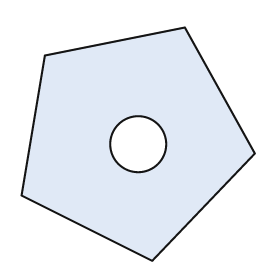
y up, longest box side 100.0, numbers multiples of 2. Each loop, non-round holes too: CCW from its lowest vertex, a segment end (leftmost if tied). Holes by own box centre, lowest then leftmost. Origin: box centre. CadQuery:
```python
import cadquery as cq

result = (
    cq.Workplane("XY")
    .moveTo(6.0, -50.0)
    .lineTo(50.0, -4.0)
    .lineTo(20.0, 50.0)
    .lineTo(-40.0, 38.0)
    .lineTo(-50.0, -22.0)
    .close()
    .moveTo(0.0, 0.0)
    .circle(12.0)
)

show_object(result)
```